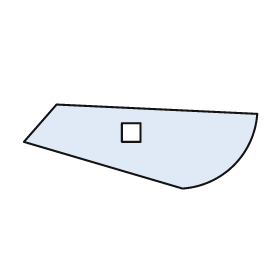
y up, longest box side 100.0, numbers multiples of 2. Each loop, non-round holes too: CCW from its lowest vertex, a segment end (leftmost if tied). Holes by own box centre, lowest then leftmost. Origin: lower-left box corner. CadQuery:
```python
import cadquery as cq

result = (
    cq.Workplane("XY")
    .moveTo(68.0, 0.0)
    .threePointArc((90.0, 10.0), (100.0, 32.0))
    .lineTo(14.0, 36.0)
    .lineTo(0.0, 20.0)
    .close()
    .moveTo(42.0, 20.0)
    .lineTo(50.0, 20.0)
    .lineTo(50.0, 28.0)
    .lineTo(42.0, 28.0)
    .close()
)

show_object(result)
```